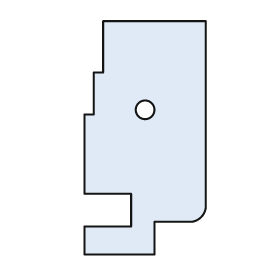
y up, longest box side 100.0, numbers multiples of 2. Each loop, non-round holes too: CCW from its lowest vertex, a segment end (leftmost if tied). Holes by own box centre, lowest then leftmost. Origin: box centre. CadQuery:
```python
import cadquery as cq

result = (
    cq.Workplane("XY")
    .moveTo(-26.0, -50.0)
    .lineTo(4.0, -50.0)
    .lineTo(4.0, -36.0)
    .lineTo(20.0, -36.0)
    .threePointArc((24.0, -34.0), (26.0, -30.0))
    .lineTo(26.0, 50.0)
    .lineTo(-18.0, 50.0)
    .lineTo(-18.0, 28.0)
    .lineTo(-22.0, 28.0)
    .lineTo(-22.0, 10.0)
    .lineTo(-26.0, 10.0)
    .lineTo(-26.0, -24.0)
    .lineTo(-6.0, -24.0)
    .lineTo(-6.0, -38.0)
    .lineTo(-26.0, -38.0)
    .close()
    .moveTo(0.0, 12.0)
    .circle(4.0)
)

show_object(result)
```